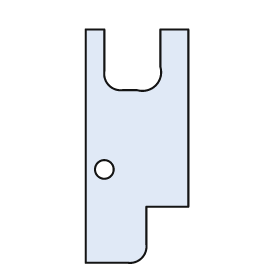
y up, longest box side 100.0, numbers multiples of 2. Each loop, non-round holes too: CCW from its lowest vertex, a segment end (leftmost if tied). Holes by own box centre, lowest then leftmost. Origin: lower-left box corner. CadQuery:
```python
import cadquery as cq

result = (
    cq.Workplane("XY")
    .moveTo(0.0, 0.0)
    .lineTo(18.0, 0.0)
    .threePointArc((24.0, 2.0), (26.0, 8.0))
    .lineTo(26.0, 24.0)
    .lineTo(44.0, 24.0)
    .lineTo(44.0, 100.0)
    .lineTo(32.0, 100.0)
    .lineTo(32.0, 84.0)
    .threePointArc((30.0, 76.0), (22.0, 74.0))
    .lineTo(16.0, 74.0)
    .threePointArc((10.0, 76.0), (8.0, 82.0))
    .lineTo(8.0, 100.0)
    .lineTo(0.0, 100.0)
    .close()
    .moveTo(8.0, 40.0)
    .circle(4.0)
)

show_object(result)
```